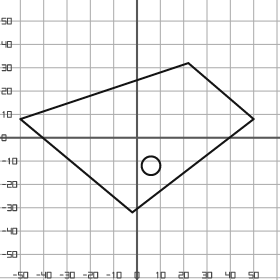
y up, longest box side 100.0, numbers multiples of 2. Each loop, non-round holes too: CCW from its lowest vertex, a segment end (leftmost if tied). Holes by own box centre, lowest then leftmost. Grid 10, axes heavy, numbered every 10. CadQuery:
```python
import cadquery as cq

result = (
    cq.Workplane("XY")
    .moveTo(-2.0, -32.0)
    .lineTo(50.0, 8.0)
    .lineTo(22.0, 32.0)
    .lineTo(-50.0, 8.0)
    .close()
    .moveTo(6.0, -12.0)
    .circle(4.0)
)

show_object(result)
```